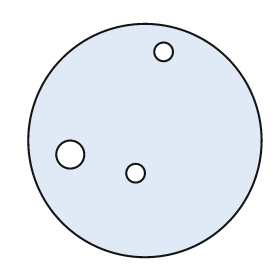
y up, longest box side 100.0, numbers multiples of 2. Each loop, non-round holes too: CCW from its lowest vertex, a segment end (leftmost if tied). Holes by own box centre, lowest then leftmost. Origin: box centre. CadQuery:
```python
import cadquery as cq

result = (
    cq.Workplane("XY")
    .moveTo(0.0, 0.0)
    .circle(50.0)
    .moveTo(-4.0, -14.0)
    .circle(4.0)
    .moveTo(-32.0, -6.0)
    .circle(6.0)
    .moveTo(8.0, 38.0)
    .circle(4.0)
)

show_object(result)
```